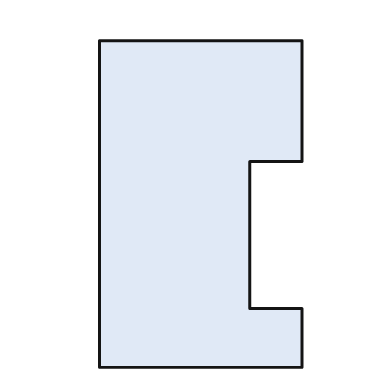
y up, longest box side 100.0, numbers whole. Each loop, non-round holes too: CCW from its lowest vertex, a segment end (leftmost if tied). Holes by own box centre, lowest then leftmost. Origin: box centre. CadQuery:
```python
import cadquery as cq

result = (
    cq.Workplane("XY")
    .moveTo(-31.0, -50.0)
    .lineTo(31.0, -50.0)
    .lineTo(31.0, -32.0)
    .lineTo(15.0, -32.0)
    .lineTo(15.0, 13.0)
    .lineTo(31.0, 13.0)
    .lineTo(31.0, 50.0)
    .lineTo(-31.0, 50.0)
    .close()
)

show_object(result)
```